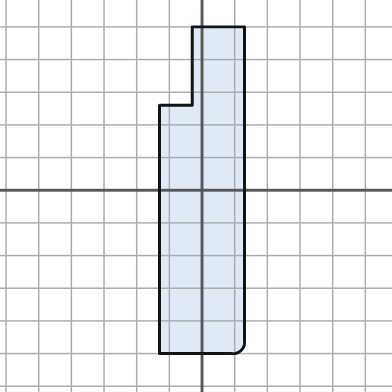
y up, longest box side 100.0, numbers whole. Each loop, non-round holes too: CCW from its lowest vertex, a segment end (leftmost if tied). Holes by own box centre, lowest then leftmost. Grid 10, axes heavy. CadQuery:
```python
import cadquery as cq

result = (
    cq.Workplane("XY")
    .moveTo(-13.0, -50.0)
    .lineTo(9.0, -50.0)
    .threePointArc((12.0, -49.0), (13.0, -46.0))
    .lineTo(13.0, 50.0)
    .lineTo(-3.0, 50.0)
    .lineTo(-3.0, 26.0)
    .lineTo(-13.0, 26.0)
    .close()
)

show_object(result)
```